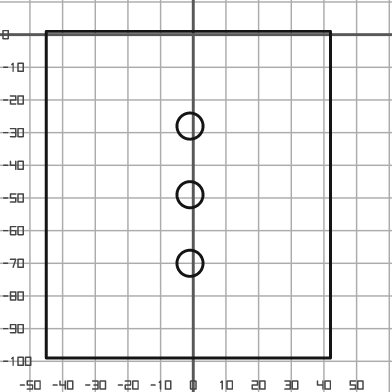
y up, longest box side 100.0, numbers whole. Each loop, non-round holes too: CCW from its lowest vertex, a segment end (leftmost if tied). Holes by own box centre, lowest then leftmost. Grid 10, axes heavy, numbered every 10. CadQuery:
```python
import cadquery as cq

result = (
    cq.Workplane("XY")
    .moveTo(-45.0, -99.0)
    .lineTo(42.0, -99.0)
    .lineTo(42.0, 1.0)
    .lineTo(-45.0, 1.0)
    .close()
    .moveTo(-1.0, -70.0)
    .circle(4.0)
    .moveTo(-1.0, -49.0)
    .circle(4.0)
    .moveTo(-1.0, -28.0)
    .circle(4.0)
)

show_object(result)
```